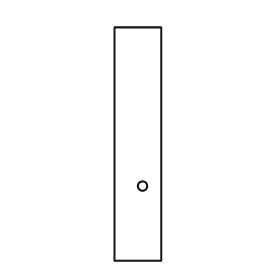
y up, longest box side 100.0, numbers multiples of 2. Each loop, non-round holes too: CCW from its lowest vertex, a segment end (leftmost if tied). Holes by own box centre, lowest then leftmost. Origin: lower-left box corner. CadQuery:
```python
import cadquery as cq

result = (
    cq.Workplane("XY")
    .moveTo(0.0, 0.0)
    .lineTo(20.0, 0.0)
    .lineTo(20.0, 100.0)
    .lineTo(0.0, 100.0)
    .close()
    .moveTo(12.0, 32.0)
    .circle(2.0)
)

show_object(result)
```